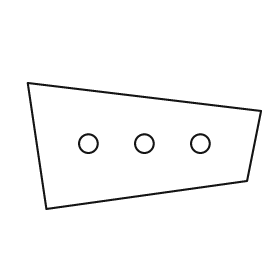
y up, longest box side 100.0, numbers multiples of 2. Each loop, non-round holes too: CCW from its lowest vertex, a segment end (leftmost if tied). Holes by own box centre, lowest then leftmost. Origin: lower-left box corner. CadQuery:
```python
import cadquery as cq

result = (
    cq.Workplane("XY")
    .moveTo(8.0, 0.0)
    .lineTo(94.0, 12.0)
    .lineTo(100.0, 42.0)
    .lineTo(0.0, 54.0)
    .close()
    .moveTo(26.0, 28.0)
    .circle(4.0)
    .moveTo(50.0, 28.0)
    .circle(4.0)
    .moveTo(74.0, 28.0)
    .circle(4.0)
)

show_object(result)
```